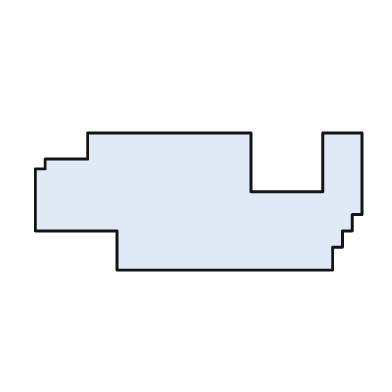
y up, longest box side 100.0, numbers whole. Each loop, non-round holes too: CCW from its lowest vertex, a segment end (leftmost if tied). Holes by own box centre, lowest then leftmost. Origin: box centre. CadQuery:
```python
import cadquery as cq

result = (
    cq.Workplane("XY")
    .moveTo(-25.0, -21.0)
    .lineTo(41.0, -21.0)
    .lineTo(41.0, -14.0)
    .lineTo(44.0, -14.0)
    .lineTo(44.0, -9.0)
    .lineTo(47.0, -9.0)
    .lineTo(47.0, -4.0)
    .lineTo(50.0, -4.0)
    .lineTo(50.0, 21.0)
    .lineTo(38.0, 21.0)
    .lineTo(38.0, 3.0)
    .lineTo(16.0, 3.0)
    .lineTo(16.0, 21.0)
    .lineTo(-34.0, 21.0)
    .lineTo(-34.0, 13.0)
    .lineTo(-47.0, 13.0)
    .lineTo(-47.0, 10.0)
    .lineTo(-50.0, 10.0)
    .lineTo(-50.0, -9.0)
    .lineTo(-25.0, -9.0)
    .close()
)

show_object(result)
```